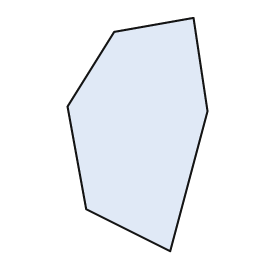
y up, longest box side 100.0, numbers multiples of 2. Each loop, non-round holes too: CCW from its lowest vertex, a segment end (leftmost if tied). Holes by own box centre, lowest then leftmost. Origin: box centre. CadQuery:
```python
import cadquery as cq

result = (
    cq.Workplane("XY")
    .moveTo(14.0, -50.0)
    .lineTo(30.0, 10.0)
    .lineTo(24.0, 50.0)
    .lineTo(-10.0, 44.0)
    .lineTo(-30.0, 12.0)
    .lineTo(-22.0, -32.0)
    .close()
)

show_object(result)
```